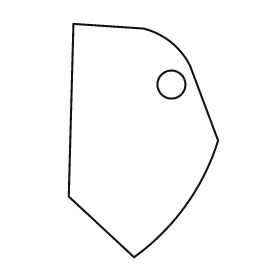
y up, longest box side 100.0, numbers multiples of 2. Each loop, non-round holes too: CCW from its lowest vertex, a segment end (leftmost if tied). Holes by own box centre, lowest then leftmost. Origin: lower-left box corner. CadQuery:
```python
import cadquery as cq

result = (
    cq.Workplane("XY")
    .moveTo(28.0, 0.0)
    .threePointArc((50.0, 22.0), (64.0, 50.0))
    .lineTo(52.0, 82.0)
    .threePointArc((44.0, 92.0), (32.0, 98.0))
    .lineTo(2.0, 100.0)
    .lineTo(0.0, 26.0)
    .close()
    .moveTo(44.0, 74.0)
    .circle(6.0)
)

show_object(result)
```